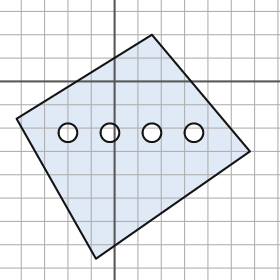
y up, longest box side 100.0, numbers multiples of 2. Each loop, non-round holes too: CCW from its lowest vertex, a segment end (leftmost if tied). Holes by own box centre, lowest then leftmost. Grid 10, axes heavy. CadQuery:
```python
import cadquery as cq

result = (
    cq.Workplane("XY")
    .moveTo(-8.0, -76.0)
    .lineTo(58.0, -30.0)
    .lineTo(16.0, 20.0)
    .lineTo(-42.0, -16.0)
    .close()
    .moveTo(-20.0, -22.0)
    .circle(4.0)
    .moveTo(-2.0, -22.0)
    .circle(4.0)
    .moveTo(16.0, -22.0)
    .circle(4.0)
    .moveTo(34.0, -22.0)
    .circle(4.0)
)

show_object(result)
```